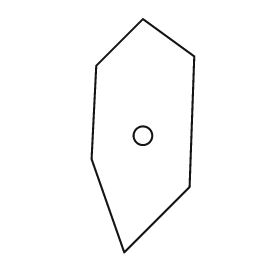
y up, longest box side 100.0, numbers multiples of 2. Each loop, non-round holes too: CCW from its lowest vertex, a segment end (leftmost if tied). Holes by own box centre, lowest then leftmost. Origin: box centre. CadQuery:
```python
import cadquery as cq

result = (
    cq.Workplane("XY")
    .moveTo(-8.0, -50.0)
    .lineTo(20.0, -22.0)
    .lineTo(22.0, 34.0)
    .lineTo(0.0, 50.0)
    .lineTo(-20.0, 30.0)
    .lineTo(-22.0, -10.0)
    .close()
    .moveTo(0.0, 0.0)
    .circle(4.0)
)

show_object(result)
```